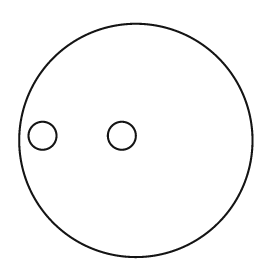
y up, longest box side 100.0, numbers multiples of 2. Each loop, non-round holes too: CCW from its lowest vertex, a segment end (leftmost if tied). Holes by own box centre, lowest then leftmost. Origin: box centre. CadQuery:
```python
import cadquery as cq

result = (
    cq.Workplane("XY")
    .moveTo(0.0, 0.0)
    .circle(50.0)
    .moveTo(-40.0, 2.0)
    .circle(6.0)
    .moveTo(-6.0, 2.0)
    .circle(6.0)
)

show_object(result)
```